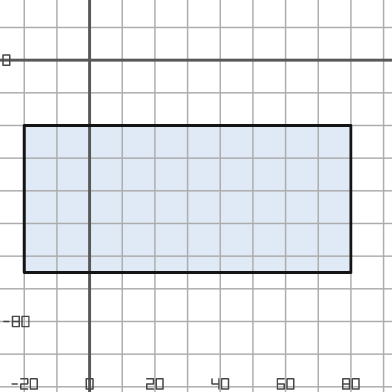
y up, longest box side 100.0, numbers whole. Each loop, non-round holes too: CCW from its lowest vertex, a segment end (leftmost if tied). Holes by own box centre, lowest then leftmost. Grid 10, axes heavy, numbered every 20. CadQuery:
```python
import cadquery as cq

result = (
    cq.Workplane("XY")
    .moveTo(-20.0, -65.0)
    .lineTo(80.0, -65.0)
    .lineTo(80.0, -20.0)
    .lineTo(-20.0, -20.0)
    .close()
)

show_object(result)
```